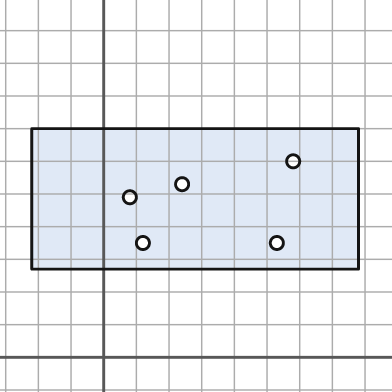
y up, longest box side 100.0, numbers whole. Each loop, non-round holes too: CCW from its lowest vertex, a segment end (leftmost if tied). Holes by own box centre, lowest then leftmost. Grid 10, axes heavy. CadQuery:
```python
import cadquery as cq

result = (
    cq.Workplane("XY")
    .moveTo(-22.0, 27.0)
    .lineTo(78.0, 27.0)
    .lineTo(78.0, 70.0)
    .lineTo(-22.0, 70.0)
    .close()
    .moveTo(12.0, 35.0)
    .circle(2.0)
    .moveTo(53.0, 35.0)
    .circle(2.0)
    .moveTo(8.0, 49.0)
    .circle(2.0)
    .moveTo(24.0, 53.0)
    .circle(2.0)
    .moveTo(58.0, 60.0)
    .circle(2.0)
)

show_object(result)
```